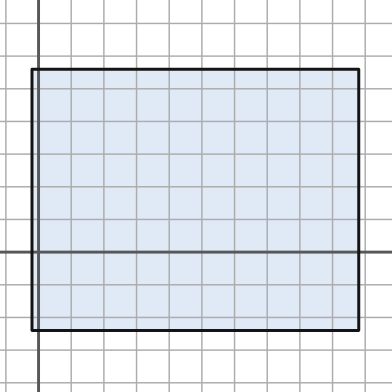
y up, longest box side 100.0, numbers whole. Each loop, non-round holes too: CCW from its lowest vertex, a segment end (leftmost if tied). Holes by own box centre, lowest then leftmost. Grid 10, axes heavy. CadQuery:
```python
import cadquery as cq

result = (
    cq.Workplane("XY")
    .moveTo(-2.0, -24.0)
    .lineTo(98.0, -24.0)
    .lineTo(98.0, 56.0)
    .lineTo(-2.0, 56.0)
    .close()
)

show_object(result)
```